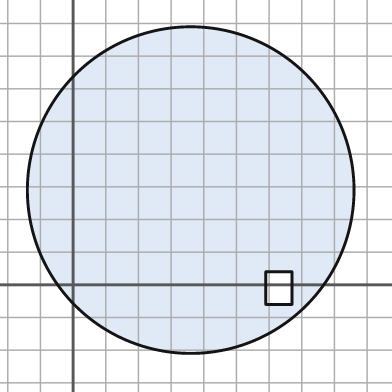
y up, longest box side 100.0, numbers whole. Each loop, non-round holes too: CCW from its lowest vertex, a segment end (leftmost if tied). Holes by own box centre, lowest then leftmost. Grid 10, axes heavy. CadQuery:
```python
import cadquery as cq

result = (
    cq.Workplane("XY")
    .moveTo(36.0, 29.0)
    .circle(50.0)
    .moveTo(59.0, -6.0)
    .lineTo(67.0, -6.0)
    .lineTo(67.0, 4.0)
    .lineTo(59.0, 4.0)
    .close()
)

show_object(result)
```